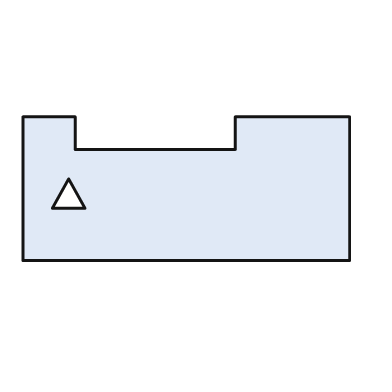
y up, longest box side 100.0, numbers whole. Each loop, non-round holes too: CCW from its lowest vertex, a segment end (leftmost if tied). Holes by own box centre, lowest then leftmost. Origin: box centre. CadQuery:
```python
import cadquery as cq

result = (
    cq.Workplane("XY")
    .moveTo(-50.0, -22.0)
    .lineTo(50.0, -22.0)
    .lineTo(50.0, 22.0)
    .lineTo(15.0, 22.0)
    .lineTo(15.0, 12.0)
    .lineTo(-34.0, 12.0)
    .lineTo(-34.0, 22.0)
    .lineTo(-50.0, 22.0)
    .close()
    .moveTo(-41.0, -6.0)
    .lineTo(-31.0, -6.0)
    .lineTo(-36.0, 3.0)
    .close()
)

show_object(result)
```